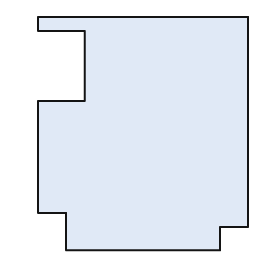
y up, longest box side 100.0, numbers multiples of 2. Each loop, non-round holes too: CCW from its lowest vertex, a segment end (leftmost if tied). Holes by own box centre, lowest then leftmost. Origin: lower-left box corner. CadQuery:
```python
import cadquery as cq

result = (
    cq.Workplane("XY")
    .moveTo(12.0, 0.0)
    .lineTo(78.0, 0.0)
    .lineTo(78.0, 10.0)
    .lineTo(90.0, 10.0)
    .lineTo(90.0, 100.0)
    .lineTo(0.0, 100.0)
    .lineTo(0.0, 94.0)
    .lineTo(20.0, 94.0)
    .lineTo(20.0, 64.0)
    .lineTo(0.0, 64.0)
    .lineTo(0.0, 16.0)
    .lineTo(12.0, 16.0)
    .close()
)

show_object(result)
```